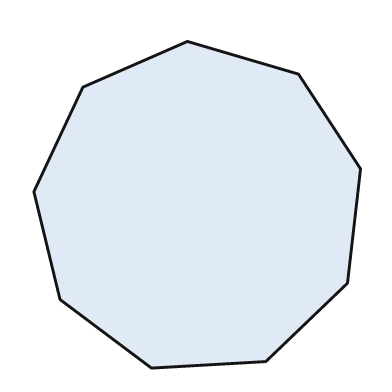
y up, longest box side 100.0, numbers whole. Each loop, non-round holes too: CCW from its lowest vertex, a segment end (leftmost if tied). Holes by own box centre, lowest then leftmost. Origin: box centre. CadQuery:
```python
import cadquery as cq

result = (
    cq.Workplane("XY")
    .moveTo(-14.0, -50.0)
    .lineTo(21.0, -48.0)
    .lineTo(46.0, -24.0)
    .lineTo(50.0, 11.0)
    .lineTo(31.0, 40.0)
    .lineTo(-3.0, 50.0)
    .lineTo(-35.0, 36.0)
    .lineTo(-50.0, 4.0)
    .lineTo(-42.0, -29.0)
    .close()
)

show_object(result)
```